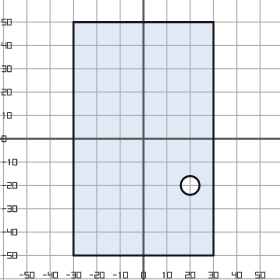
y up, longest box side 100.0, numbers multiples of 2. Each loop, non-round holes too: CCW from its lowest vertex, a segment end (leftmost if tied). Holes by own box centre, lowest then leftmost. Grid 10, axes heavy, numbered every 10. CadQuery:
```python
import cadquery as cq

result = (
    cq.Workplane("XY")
    .moveTo(-30.0, -50.0)
    .lineTo(30.0, -50.0)
    .lineTo(30.0, 50.0)
    .lineTo(-30.0, 50.0)
    .close()
    .moveTo(20.0, -20.0)
    .circle(4.0)
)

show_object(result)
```